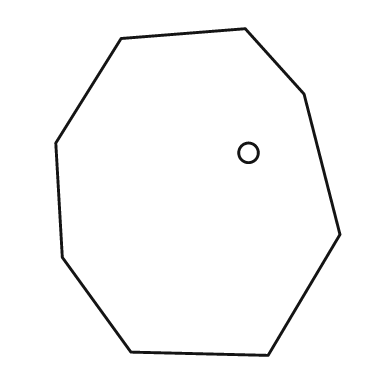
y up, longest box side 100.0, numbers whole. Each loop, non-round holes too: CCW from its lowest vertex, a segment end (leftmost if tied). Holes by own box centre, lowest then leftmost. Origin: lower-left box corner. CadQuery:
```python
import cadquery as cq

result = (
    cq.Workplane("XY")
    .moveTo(65.0, 0.0)
    .lineTo(87.0, 37.0)
    .lineTo(76.0, 80.0)
    .lineTo(58.0, 100.0)
    .lineTo(20.0, 97.0)
    .lineTo(0.0, 65.0)
    .lineTo(2.0, 30.0)
    .lineTo(23.0, 1.0)
    .close()
    .moveTo(59.0, 62.0)
    .circle(3.0)
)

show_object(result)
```